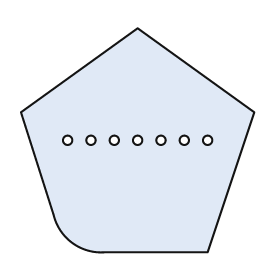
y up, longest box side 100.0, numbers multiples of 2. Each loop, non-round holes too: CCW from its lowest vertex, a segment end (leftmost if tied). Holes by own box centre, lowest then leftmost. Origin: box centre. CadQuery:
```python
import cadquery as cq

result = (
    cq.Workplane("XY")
    .moveTo(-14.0, -48.0)
    .lineTo(30.0, -48.0)
    .lineTo(50.0, 12.0)
    .lineTo(0.0, 48.0)
    .lineTo(-50.0, 12.0)
    .lineTo(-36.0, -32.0)
    .threePointArc((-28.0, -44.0), (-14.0, -48.0))
    .close()
    .moveTo(-30.0, 0.0)
    .circle(2.0)
    .moveTo(-20.0, 0.0)
    .circle(2.0)
    .moveTo(-10.0, 0.0)
    .circle(2.0)
    .moveTo(0.0, 0.0)
    .circle(2.0)
    .moveTo(10.0, 0.0)
    .circle(2.0)
    .moveTo(20.0, 0.0)
    .circle(2.0)
    .moveTo(30.0, 0.0)
    .circle(2.0)
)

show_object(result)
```